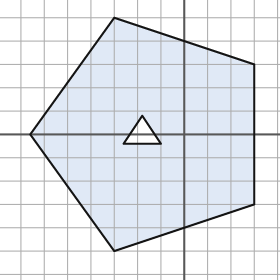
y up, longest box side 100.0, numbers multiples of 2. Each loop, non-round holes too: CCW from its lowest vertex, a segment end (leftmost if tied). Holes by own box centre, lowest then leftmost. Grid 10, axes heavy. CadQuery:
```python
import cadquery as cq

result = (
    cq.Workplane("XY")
    .moveTo(-30.0, -50.0)
    .lineTo(30.0, -30.0)
    .lineTo(30.0, 30.0)
    .lineTo(-30.0, 50.0)
    .lineTo(-66.0, 0.0)
    .close()
    .moveTo(-26.0, -4.0)
    .lineTo(-10.0, -4.0)
    .lineTo(-18.0, 8.0)
    .close()
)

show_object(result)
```